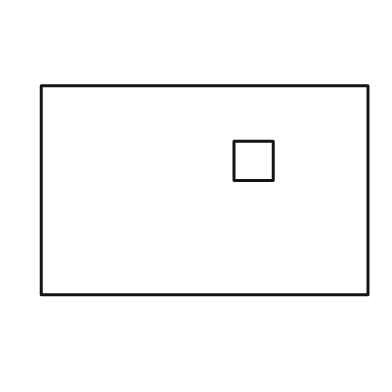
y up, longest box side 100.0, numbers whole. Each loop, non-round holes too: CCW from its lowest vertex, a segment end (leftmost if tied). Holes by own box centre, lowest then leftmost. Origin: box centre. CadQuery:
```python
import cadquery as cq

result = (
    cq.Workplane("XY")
    .moveTo(-50.0, -32.0)
    .lineTo(50.0, -32.0)
    .lineTo(50.0, 32.0)
    .lineTo(-50.0, 32.0)
    .close()
    .moveTo(9.0, 3.0)
    .lineTo(21.0, 3.0)
    .lineTo(21.0, 15.0)
    .lineTo(9.0, 15.0)
    .close()
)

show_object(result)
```